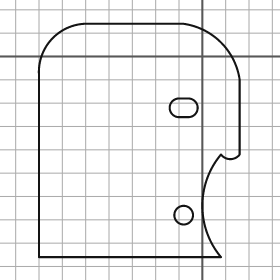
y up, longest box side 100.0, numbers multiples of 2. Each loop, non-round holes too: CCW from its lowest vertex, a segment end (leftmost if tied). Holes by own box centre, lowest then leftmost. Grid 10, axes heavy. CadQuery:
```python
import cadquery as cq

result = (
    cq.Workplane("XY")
    .moveTo(-70.0, -86.0)
    .lineTo(8.0, -86.0)
    .threePointArc((0.0, -64.0), (8.0, -42.0))
    .threePointArc((12.0, -44.0), (16.0, -42.0))
    .lineTo(16.0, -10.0)
    .threePointArc((8.0, 6.0), (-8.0, 14.0))
    .lineTo(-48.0, 14.0)
    .threePointArc((-64.0, 8.0), (-70.0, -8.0))
    .close()
    .moveTo(-8.0, -68.0)
    .circle(4.0)
    .moveTo(-10.0, -26.0)
    .lineTo(-6.0, -26.0)
    .threePointArc((-2.0, -22.0), (-6.0, -18.0))
    .lineTo(-10.0, -18.0)
    .threePointArc((-14.0, -22.0), (-10.0, -26.0))
    .close()
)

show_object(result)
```